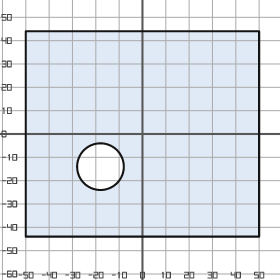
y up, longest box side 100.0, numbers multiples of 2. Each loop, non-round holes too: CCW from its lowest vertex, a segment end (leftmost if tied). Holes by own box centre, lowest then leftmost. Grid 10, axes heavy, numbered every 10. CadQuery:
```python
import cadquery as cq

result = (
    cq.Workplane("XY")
    .moveTo(-50.0, -44.0)
    .lineTo(50.0, -44.0)
    .lineTo(50.0, 44.0)
    .lineTo(-50.0, 44.0)
    .close()
    .moveTo(-18.0, -14.0)
    .circle(10.0)
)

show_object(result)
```